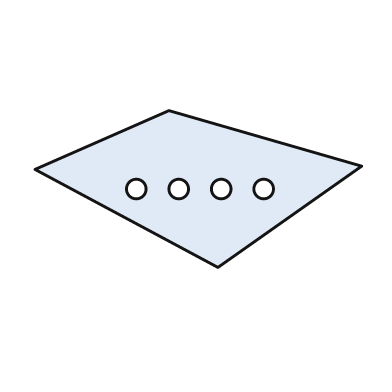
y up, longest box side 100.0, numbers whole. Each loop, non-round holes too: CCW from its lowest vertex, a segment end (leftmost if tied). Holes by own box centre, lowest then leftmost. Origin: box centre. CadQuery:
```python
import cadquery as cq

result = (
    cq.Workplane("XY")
    .moveTo(6.0, -24.0)
    .lineTo(50.0, 7.0)
    .lineTo(-9.0, 24.0)
    .lineTo(-50.0, 6.0)
    .close()
    .moveTo(-19.0, 0.0)
    .circle(3.0)
    .moveTo(-6.0, 0.0)
    .circle(3.0)
    .moveTo(7.0, 0.0)
    .circle(3.0)
    .moveTo(20.0, 0.0)
    .circle(3.0)
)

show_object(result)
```